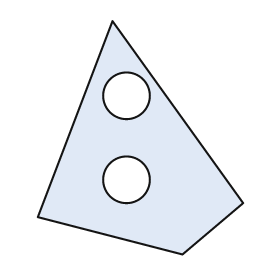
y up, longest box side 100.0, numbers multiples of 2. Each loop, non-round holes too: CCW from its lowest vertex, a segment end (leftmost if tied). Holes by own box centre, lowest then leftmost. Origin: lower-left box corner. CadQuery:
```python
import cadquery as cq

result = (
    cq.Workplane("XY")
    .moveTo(62.0, 0.0)
    .lineTo(88.0, 22.0)
    .lineTo(32.0, 100.0)
    .lineTo(0.0, 16.0)
    .close()
    .moveTo(38.0, 32.0)
    .circle(10.0)
    .moveTo(38.0, 68.0)
    .circle(10.0)
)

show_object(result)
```